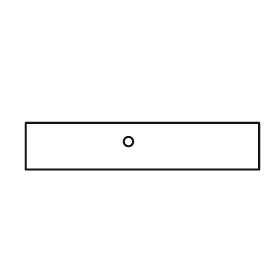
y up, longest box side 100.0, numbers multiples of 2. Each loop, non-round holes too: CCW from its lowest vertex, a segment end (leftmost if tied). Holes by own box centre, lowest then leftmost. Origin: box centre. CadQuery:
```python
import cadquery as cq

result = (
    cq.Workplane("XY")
    .moveTo(-50.0, -10.0)
    .lineTo(50.0, -10.0)
    .lineTo(50.0, 10.0)
    .lineTo(-50.0, 10.0)
    .close()
    .moveTo(-6.0, 2.0)
    .circle(2.0)
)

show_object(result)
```